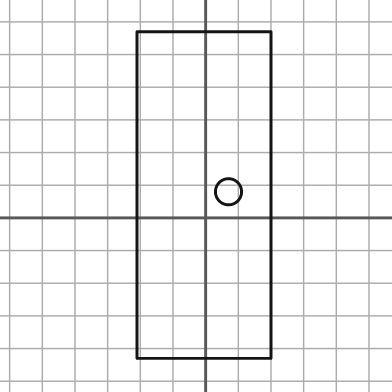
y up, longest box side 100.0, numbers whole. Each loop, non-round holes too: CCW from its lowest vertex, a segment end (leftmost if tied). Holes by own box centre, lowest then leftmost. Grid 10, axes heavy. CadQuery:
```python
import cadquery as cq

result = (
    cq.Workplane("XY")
    .moveTo(-21.0, -43.0)
    .lineTo(20.0, -43.0)
    .lineTo(20.0, 57.0)
    .lineTo(-21.0, 57.0)
    .close()
    .moveTo(7.0, 8.0)
    .circle(4.0)
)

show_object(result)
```